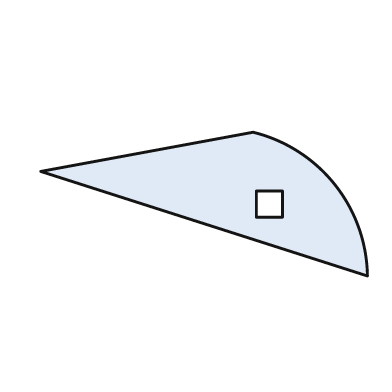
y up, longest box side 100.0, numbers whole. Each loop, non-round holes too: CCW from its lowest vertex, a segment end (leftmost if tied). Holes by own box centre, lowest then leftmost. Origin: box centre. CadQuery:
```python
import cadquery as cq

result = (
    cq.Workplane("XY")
    .moveTo(50.0, -22.0)
    .threePointArc((40.0, 6.0), (15.0, 22.0))
    .lineTo(-50.0, 10.0)
    .close()
    .moveTo(16.0, -4.0)
    .lineTo(24.0, -4.0)
    .lineTo(24.0, 4.0)
    .lineTo(16.0, 4.0)
    .close()
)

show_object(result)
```